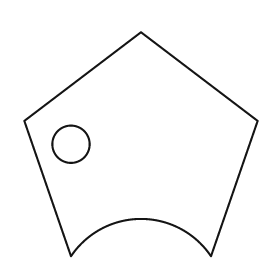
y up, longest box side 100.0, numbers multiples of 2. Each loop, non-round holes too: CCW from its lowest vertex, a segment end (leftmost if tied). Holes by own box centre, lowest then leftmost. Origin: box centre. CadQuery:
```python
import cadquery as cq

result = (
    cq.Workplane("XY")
    .moveTo(-30.0, -48.0)
    .threePointArc((0.0, -32.0), (30.0, -48.0))
    .lineTo(50.0, 10.0)
    .lineTo(0.0, 48.0)
    .lineTo(-50.0, 10.0)
    .close()
    .moveTo(-30.0, 0.0)
    .circle(8.0)
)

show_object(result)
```